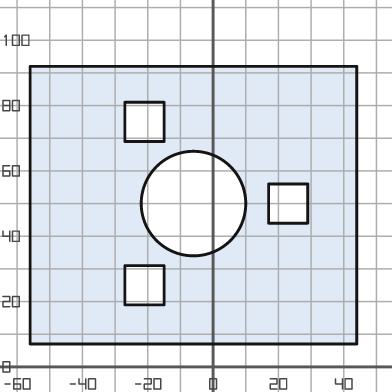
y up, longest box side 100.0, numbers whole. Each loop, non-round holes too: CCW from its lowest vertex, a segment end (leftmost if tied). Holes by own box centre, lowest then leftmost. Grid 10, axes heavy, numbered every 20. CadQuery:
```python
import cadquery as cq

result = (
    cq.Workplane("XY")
    .moveTo(-56.0, 7.0)
    .lineTo(44.0, 7.0)
    .lineTo(44.0, 92.0)
    .lineTo(-56.0, 92.0)
    .close()
    .moveTo(-27.0, 19.0)
    .lineTo(-15.0, 19.0)
    .lineTo(-15.0, 31.0)
    .lineTo(-27.0, 31.0)
    .close()
    .moveTo(-6.0, 50.0)
    .circle(16.0)
    .moveTo(17.0, 44.0)
    .lineTo(29.0, 44.0)
    .lineTo(29.0, 56.0)
    .lineTo(17.0, 56.0)
    .close()
    .moveTo(-27.0, 69.0)
    .lineTo(-15.0, 69.0)
    .lineTo(-15.0, 81.0)
    .lineTo(-27.0, 81.0)
    .close()
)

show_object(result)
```